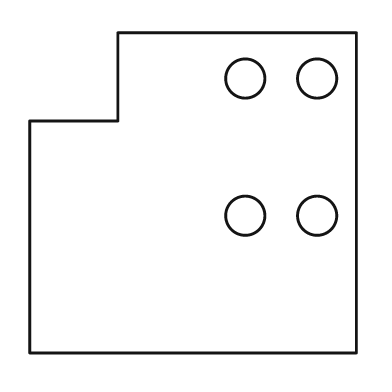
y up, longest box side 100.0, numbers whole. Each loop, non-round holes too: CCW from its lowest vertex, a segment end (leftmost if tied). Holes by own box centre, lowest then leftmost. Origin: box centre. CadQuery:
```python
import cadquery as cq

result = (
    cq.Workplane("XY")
    .moveTo(-50.0, -49.0)
    .lineTo(50.0, -49.0)
    .lineTo(50.0, 49.0)
    .lineTo(-23.0, 49.0)
    .lineTo(-23.0, 22.0)
    .lineTo(-50.0, 22.0)
    .close()
    .moveTo(16.0, -7.0)
    .circle(6.0)
    .moveTo(38.0, -7.0)
    .circle(6.0)
    .moveTo(16.0, 35.0)
    .circle(6.0)
    .moveTo(38.0, 35.0)
    .circle(6.0)
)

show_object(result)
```